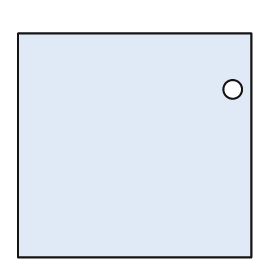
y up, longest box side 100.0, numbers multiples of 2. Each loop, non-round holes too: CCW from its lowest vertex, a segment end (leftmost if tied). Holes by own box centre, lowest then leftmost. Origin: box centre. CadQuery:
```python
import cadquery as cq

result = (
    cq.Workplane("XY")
    .moveTo(-50.0, -48.0)
    .lineTo(50.0, -48.0)
    .lineTo(50.0, 48.0)
    .lineTo(-50.0, 48.0)
    .close()
    .moveTo(42.0, 24.0)
    .circle(4.0)
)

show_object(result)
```